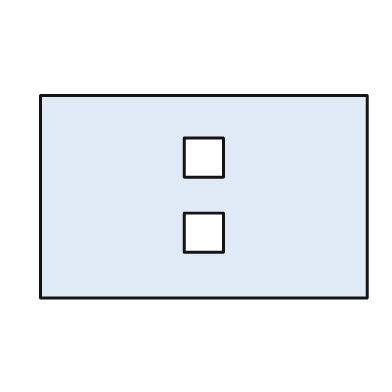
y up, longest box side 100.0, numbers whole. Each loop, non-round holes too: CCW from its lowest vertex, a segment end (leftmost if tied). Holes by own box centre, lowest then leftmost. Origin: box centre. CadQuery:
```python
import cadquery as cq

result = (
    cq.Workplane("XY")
    .moveTo(-50.0, -31.0)
    .lineTo(50.0, -31.0)
    .lineTo(50.0, 31.0)
    .lineTo(-50.0, 31.0)
    .close()
    .moveTo(-6.0, -17.0)
    .lineTo(6.0, -17.0)
    .lineTo(6.0, -5.0)
    .lineTo(-6.0, -5.0)
    .close()
    .moveTo(-6.0, 6.0)
    .lineTo(6.0, 6.0)
    .lineTo(6.0, 18.0)
    .lineTo(-6.0, 18.0)
    .close()
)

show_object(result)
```